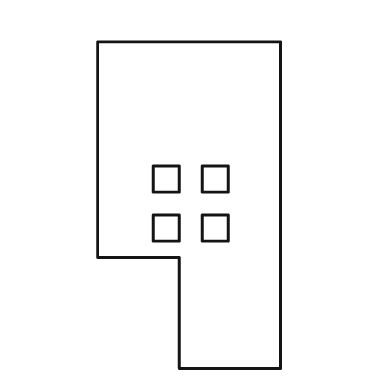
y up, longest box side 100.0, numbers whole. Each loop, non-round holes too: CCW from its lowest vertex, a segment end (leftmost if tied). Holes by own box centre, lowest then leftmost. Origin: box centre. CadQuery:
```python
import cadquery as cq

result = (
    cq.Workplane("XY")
    .moveTo(-3.0, -50.0)
    .lineTo(28.0, -50.0)
    .lineTo(28.0, 50.0)
    .lineTo(-28.0, 50.0)
    .lineTo(-28.0, -16.0)
    .lineTo(-3.0, -16.0)
    .close()
    .moveTo(-11.0, -11.0)
    .lineTo(-3.0, -11.0)
    .lineTo(-3.0, -3.0)
    .lineTo(-11.0, -3.0)
    .close()
    .moveTo(4.0, -11.0)
    .lineTo(12.0, -11.0)
    .lineTo(12.0, -3.0)
    .lineTo(4.0, -3.0)
    .close()
    .moveTo(-11.0, 4.0)
    .lineTo(-3.0, 4.0)
    .lineTo(-3.0, 12.0)
    .lineTo(-11.0, 12.0)
    .close()
    .moveTo(4.0, 4.0)
    .lineTo(12.0, 4.0)
    .lineTo(12.0, 12.0)
    .lineTo(4.0, 12.0)
    .close()
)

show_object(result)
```